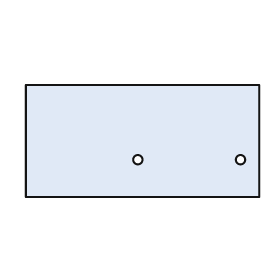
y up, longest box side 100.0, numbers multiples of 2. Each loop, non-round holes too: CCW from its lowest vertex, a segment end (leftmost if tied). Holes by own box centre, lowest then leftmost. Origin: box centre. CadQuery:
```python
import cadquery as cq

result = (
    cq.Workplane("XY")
    .moveTo(-50.0, -24.0)
    .lineTo(50.0, -24.0)
    .lineTo(50.0, 24.0)
    .lineTo(-50.0, 24.0)
    .close()
    .moveTo(-2.0, -8.0)
    .circle(2.0)
    .moveTo(42.0, -8.0)
    .circle(2.0)
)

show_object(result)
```